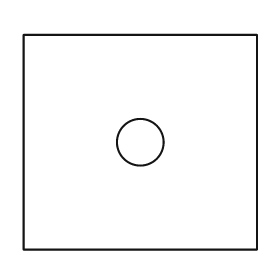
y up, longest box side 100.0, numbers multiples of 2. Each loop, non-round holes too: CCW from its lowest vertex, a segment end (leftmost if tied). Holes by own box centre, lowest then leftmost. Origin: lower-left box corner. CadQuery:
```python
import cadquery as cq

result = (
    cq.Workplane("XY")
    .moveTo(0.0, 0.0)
    .lineTo(100.0, 0.0)
    .lineTo(100.0, 92.0)
    .lineTo(0.0, 92.0)
    .close()
    .moveTo(50.0, 46.0)
    .circle(10.0)
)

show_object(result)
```